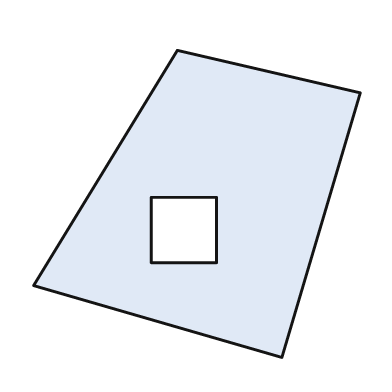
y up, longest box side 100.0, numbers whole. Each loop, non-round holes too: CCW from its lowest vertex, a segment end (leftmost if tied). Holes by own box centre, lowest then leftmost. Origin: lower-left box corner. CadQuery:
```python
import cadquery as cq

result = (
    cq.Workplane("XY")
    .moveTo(76.0, 0.0)
    .lineTo(100.0, 81.0)
    .lineTo(44.0, 94.0)
    .lineTo(0.0, 22.0)
    .close()
    .moveTo(36.0, 29.0)
    .lineTo(56.0, 29.0)
    .lineTo(56.0, 49.0)
    .lineTo(36.0, 49.0)
    .close()
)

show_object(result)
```